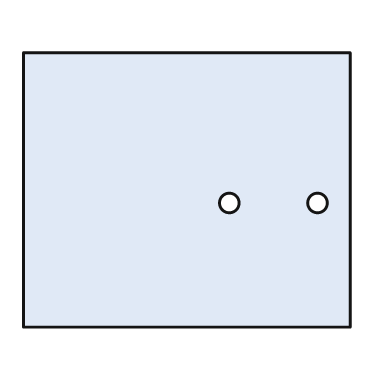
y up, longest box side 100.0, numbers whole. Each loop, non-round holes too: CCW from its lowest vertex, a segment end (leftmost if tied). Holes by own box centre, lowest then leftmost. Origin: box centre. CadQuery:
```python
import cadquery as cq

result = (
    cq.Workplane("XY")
    .moveTo(-50.0, -42.0)
    .lineTo(50.0, -42.0)
    .lineTo(50.0, 42.0)
    .lineTo(-50.0, 42.0)
    .close()
    .moveTo(13.0, -4.0)
    .circle(3.0)
    .moveTo(40.0, -4.0)
    .circle(3.0)
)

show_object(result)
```